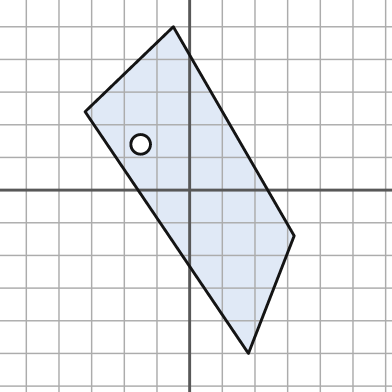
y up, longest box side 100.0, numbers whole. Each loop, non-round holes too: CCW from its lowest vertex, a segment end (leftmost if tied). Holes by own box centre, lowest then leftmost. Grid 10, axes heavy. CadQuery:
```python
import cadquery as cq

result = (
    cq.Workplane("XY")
    .moveTo(18.0, -50.0)
    .lineTo(32.0, -14.0)
    .lineTo(-5.0, 50.0)
    .lineTo(-32.0, 24.0)
    .close()
    .moveTo(-15.0, 14.0)
    .circle(3.0)
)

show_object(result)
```